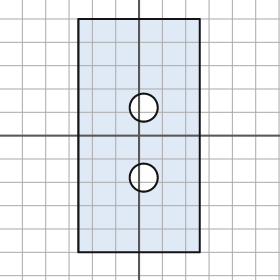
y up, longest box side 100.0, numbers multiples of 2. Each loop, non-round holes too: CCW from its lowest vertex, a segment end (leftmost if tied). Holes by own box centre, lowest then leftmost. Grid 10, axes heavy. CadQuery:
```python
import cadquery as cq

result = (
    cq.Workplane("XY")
    .moveTo(-26.0, -50.0)
    .lineTo(26.0, -50.0)
    .lineTo(26.0, 50.0)
    .lineTo(-26.0, 50.0)
    .close()
    .moveTo(2.0, -18.0)
    .circle(6.0)
    .moveTo(2.0, 12.0)
    .circle(6.0)
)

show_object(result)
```